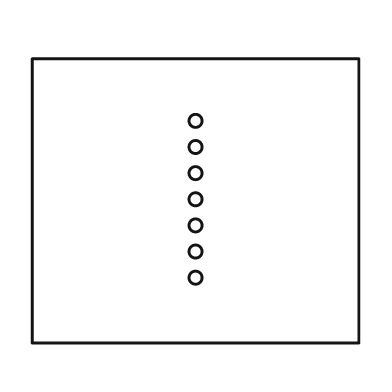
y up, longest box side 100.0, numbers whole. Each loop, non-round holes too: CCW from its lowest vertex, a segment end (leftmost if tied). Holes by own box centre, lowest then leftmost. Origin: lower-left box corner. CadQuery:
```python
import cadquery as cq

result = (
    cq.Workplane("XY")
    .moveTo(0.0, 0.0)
    .lineTo(100.0, 0.0)
    .lineTo(100.0, 87.0)
    .lineTo(0.0, 87.0)
    .close()
    .moveTo(50.0, 20.0)
    .circle(2.0)
    .moveTo(50.0, 28.0)
    .circle(2.0)
    .moveTo(50.0, 36.0)
    .circle(2.0)
    .moveTo(50.0, 44.0)
    .circle(2.0)
    .moveTo(50.0, 52.0)
    .circle(2.0)
    .moveTo(50.0, 60.0)
    .circle(2.0)
    .moveTo(50.0, 68.0)
    .circle(2.0)
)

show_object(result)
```